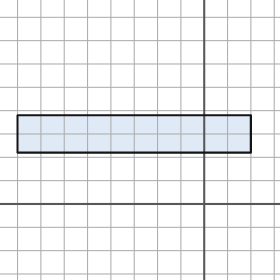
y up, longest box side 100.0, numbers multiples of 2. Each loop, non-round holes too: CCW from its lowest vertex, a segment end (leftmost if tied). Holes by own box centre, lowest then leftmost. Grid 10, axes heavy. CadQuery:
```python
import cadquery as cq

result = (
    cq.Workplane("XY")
    .moveTo(-80.0, 22.0)
    .lineTo(20.0, 22.0)
    .lineTo(20.0, 38.0)
    .lineTo(-80.0, 38.0)
    .close()
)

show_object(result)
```